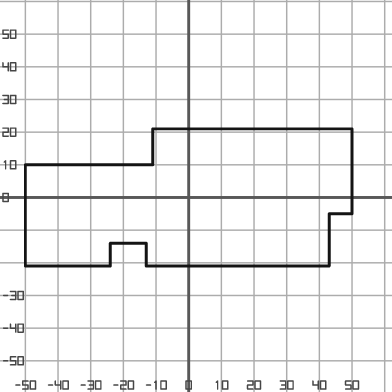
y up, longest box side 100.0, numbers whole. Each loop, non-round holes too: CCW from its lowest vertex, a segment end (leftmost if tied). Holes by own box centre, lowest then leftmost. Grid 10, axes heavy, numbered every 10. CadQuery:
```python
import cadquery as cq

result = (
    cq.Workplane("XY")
    .moveTo(-50.0, -21.0)
    .lineTo(-24.0, -21.0)
    .lineTo(-24.0, -14.0)
    .lineTo(-13.0, -14.0)
    .lineTo(-13.0, -21.0)
    .lineTo(43.0, -21.0)
    .lineTo(43.0, -5.0)
    .lineTo(50.0, -5.0)
    .lineTo(50.0, 21.0)
    .lineTo(-11.0, 21.0)
    .lineTo(-11.0, 10.0)
    .lineTo(-50.0, 10.0)
    .close()
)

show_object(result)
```